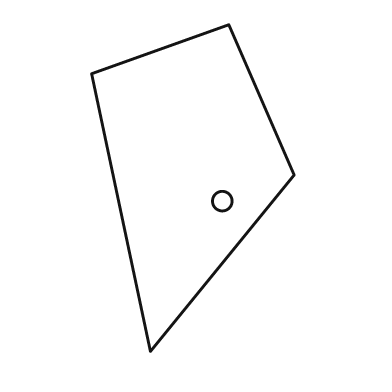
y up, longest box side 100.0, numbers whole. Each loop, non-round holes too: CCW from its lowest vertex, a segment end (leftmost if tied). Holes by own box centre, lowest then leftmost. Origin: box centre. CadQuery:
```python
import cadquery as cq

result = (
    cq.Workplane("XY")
    .moveTo(-13.0, -50.0)
    .lineTo(31.0, 4.0)
    .lineTo(11.0, 50.0)
    .lineTo(-31.0, 35.0)
    .close()
    .moveTo(9.0, -4.0)
    .circle(3.0)
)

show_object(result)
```